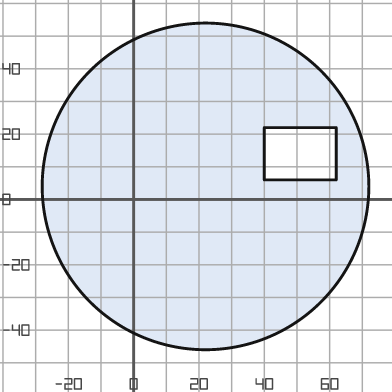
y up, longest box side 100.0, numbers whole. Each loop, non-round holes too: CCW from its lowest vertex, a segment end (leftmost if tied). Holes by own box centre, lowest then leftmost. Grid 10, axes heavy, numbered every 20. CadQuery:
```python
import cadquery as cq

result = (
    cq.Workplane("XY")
    .moveTo(22.0, 4.0)
    .circle(50.0)
    .moveTo(40.0, 6.0)
    .lineTo(62.0, 6.0)
    .lineTo(62.0, 22.0)
    .lineTo(40.0, 22.0)
    .close()
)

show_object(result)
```